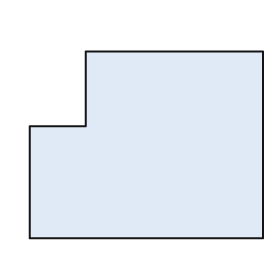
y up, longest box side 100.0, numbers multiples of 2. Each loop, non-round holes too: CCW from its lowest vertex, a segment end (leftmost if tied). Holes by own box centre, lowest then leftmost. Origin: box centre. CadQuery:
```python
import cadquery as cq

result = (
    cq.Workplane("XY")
    .moveTo(-50.0, -40.0)
    .lineTo(50.0, -40.0)
    .lineTo(50.0, 40.0)
    .lineTo(-26.0, 40.0)
    .lineTo(-26.0, 8.0)
    .lineTo(-50.0, 8.0)
    .close()
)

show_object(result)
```